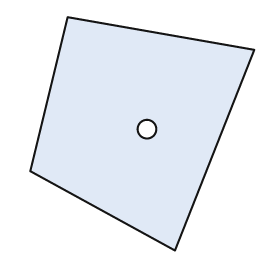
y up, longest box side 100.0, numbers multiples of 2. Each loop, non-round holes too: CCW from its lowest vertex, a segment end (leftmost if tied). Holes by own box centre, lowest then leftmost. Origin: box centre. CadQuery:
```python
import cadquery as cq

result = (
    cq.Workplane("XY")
    .moveTo(14.0, -50.0)
    .lineTo(48.0, 36.0)
    .lineTo(-32.0, 50.0)
    .lineTo(-48.0, -16.0)
    .close()
    .moveTo(2.0, 2.0)
    .circle(4.0)
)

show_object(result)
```